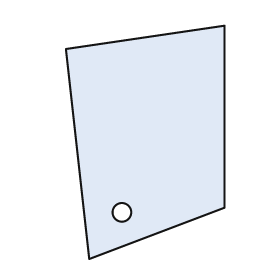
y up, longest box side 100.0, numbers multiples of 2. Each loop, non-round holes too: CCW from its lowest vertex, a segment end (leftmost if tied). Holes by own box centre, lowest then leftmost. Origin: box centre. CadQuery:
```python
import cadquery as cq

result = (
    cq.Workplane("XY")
    .moveTo(-24.0, -50.0)
    .lineTo(34.0, -28.0)
    .lineTo(34.0, 50.0)
    .lineTo(-34.0, 40.0)
    .close()
    .moveTo(-10.0, -30.0)
    .circle(4.0)
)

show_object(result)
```